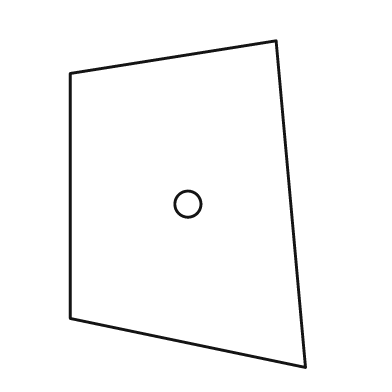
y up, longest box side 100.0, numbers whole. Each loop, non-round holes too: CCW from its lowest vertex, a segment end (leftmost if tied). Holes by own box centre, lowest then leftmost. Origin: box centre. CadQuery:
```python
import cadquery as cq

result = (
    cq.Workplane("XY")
    .moveTo(36.0, -50.0)
    .lineTo(27.0, 50.0)
    .lineTo(-36.0, 40.0)
    .lineTo(-36.0, -35.0)
    .close()
    .moveTo(0.0, 0.0)
    .circle(4.0)
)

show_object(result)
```